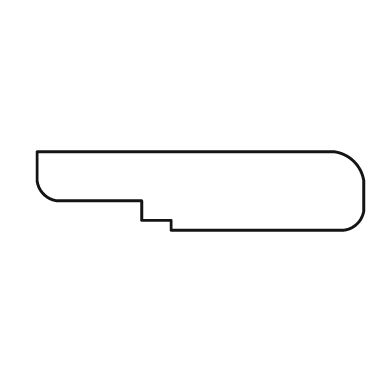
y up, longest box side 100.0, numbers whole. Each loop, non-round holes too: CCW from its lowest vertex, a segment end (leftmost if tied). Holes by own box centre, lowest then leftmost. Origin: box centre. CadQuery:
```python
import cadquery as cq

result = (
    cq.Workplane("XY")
    .moveTo(-9.0, -12.0)
    .lineTo(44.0, -12.0)
    .threePointArc((48.0, -10.0), (50.0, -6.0))
    .lineTo(50.0, 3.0)
    .threePointArc((47.0, 9.0), (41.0, 12.0))
    .lineTo(-50.0, 12.0)
    .lineTo(-50.0, 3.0)
    .threePointArc((-48.0, -1.0), (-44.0, -3.0))
    .lineTo(-18.0, -3.0)
    .lineTo(-18.0, -9.0)
    .lineTo(-9.0, -9.0)
    .close()
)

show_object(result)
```